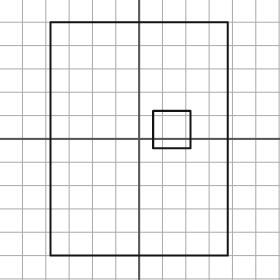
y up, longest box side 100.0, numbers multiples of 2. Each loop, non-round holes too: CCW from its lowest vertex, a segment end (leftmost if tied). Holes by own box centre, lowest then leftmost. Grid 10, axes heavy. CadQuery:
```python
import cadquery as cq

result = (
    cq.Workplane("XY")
    .moveTo(-38.0, -50.0)
    .lineTo(38.0, -50.0)
    .lineTo(38.0, 50.0)
    .lineTo(-38.0, 50.0)
    .close()
    .moveTo(6.0, -4.0)
    .lineTo(22.0, -4.0)
    .lineTo(22.0, 12.0)
    .lineTo(6.0, 12.0)
    .close()
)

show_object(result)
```